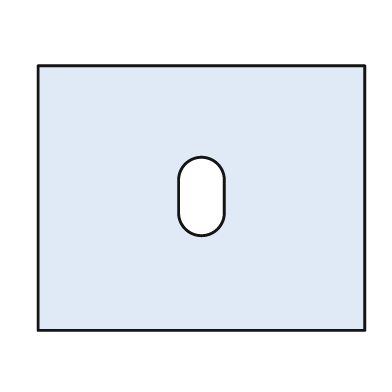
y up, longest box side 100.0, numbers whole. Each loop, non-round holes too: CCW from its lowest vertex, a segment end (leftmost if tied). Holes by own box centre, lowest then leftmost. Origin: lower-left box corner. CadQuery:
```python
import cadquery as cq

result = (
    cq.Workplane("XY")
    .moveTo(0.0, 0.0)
    .lineTo(100.0, 0.0)
    .lineTo(100.0, 81.0)
    .lineTo(0.0, 81.0)
    .close()
    .moveTo(43.0, 36.0)
    .threePointArc((50.0, 29.0), (57.0, 36.0))
    .lineTo(57.0, 46.0)
    .threePointArc((50.0, 53.0), (43.0, 46.0))
    .close()
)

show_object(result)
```